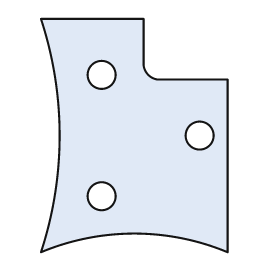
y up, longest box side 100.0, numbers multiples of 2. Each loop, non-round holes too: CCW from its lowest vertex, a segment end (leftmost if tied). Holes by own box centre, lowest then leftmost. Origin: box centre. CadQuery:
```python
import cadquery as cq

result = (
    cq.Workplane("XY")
    .moveTo(-40.0, -50.0)
    .threePointArc((0.0, -42.0), (40.0, -50.0))
    .lineTo(40.0, 24.0)
    .lineTo(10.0, 24.0)
    .threePointArc((6.0, 26.0), (4.0, 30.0))
    .lineTo(4.0, 50.0)
    .lineTo(-40.0, 50.0)
    .threePointArc((-32.0, 0.0), (-40.0, -50.0))
    .close()
    .moveTo(-14.0, -26.0)
    .circle(6.0)
    .moveTo(28.0, 0.0)
    .circle(6.0)
    .moveTo(-14.0, 26.0)
    .circle(6.0)
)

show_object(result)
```